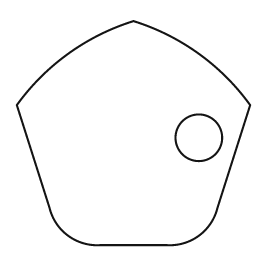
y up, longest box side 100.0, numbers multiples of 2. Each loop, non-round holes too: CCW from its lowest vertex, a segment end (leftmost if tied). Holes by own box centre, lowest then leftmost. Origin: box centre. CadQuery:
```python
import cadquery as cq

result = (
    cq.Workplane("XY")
    .moveTo(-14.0, -48.0)
    .lineTo(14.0, -48.0)
    .threePointArc((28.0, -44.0), (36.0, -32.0))
    .lineTo(50.0, 12.0)
    .threePointArc((28.0, 34.0), (0.0, 48.0))
    .threePointArc((-28.0, 34.0), (-50.0, 12.0))
    .lineTo(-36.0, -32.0)
    .threePointArc((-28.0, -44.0), (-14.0, -48.0))
    .close()
    .moveTo(28.0, -2.0)
    .circle(10.0)
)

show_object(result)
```